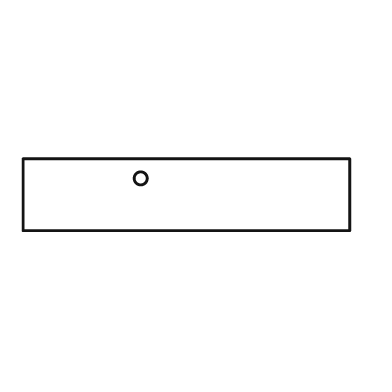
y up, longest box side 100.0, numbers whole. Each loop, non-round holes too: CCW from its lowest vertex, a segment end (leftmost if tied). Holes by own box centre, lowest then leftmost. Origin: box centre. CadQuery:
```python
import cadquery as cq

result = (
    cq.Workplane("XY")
    .moveTo(-50.0, -11.0)
    .lineTo(50.0, -11.0)
    .lineTo(50.0, 11.0)
    .lineTo(-50.0, 11.0)
    .close()
    .moveTo(-14.0, 5.0)
    .circle(2.0)
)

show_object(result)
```